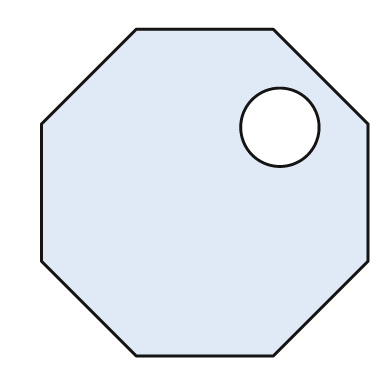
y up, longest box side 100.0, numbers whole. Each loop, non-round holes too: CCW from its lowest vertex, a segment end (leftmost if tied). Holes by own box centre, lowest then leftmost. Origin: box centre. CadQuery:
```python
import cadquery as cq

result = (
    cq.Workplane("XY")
    .moveTo(-21.0, -50.0)
    .lineTo(21.0, -50.0)
    .lineTo(50.0, -21.0)
    .lineTo(50.0, 21.0)
    .lineTo(21.0, 50.0)
    .lineTo(-21.0, 50.0)
    .lineTo(-50.0, 21.0)
    .lineTo(-50.0, -21.0)
    .close()
    .moveTo(23.0, 20.0)
    .circle(12.0)
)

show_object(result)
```